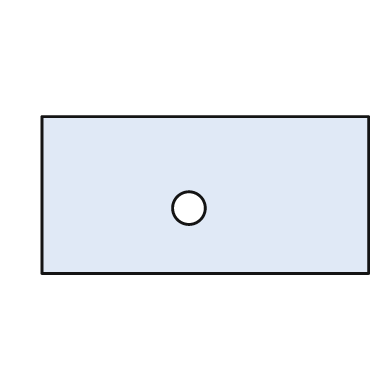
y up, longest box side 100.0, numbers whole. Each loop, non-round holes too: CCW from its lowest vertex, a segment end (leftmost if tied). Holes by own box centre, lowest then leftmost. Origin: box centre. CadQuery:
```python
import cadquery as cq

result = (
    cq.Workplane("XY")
    .moveTo(-50.0, -24.0)
    .lineTo(50.0, -24.0)
    .lineTo(50.0, 24.0)
    .lineTo(-50.0, 24.0)
    .close()
    .moveTo(-5.0, -4.0)
    .circle(5.0)
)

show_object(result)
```